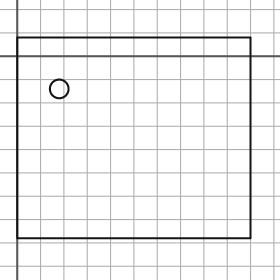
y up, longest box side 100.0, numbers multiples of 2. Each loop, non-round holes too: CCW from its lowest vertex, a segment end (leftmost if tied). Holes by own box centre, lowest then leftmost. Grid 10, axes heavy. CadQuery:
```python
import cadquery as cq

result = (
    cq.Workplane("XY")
    .moveTo(0.0, -78.0)
    .lineTo(100.0, -78.0)
    .lineTo(100.0, 8.0)
    .lineTo(0.0, 8.0)
    .close()
    .moveTo(18.0, -14.0)
    .circle(4.0)
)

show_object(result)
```